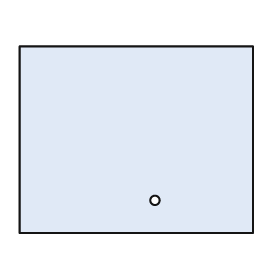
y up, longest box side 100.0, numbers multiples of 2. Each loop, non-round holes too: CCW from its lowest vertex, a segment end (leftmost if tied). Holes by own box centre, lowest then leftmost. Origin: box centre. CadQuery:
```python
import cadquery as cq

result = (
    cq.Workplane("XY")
    .moveTo(-50.0, -40.0)
    .lineTo(50.0, -40.0)
    .lineTo(50.0, 40.0)
    .lineTo(-50.0, 40.0)
    .close()
    .moveTo(8.0, -26.0)
    .circle(2.0)
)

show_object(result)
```